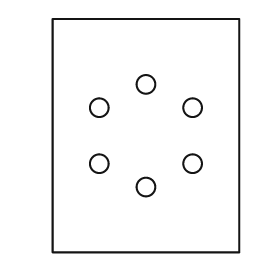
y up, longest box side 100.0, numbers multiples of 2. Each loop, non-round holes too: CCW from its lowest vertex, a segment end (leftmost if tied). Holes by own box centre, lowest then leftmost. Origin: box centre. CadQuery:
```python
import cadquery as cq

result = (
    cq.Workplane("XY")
    .moveTo(-40.0, -50.0)
    .lineTo(40.0, -50.0)
    .lineTo(40.0, 50.0)
    .lineTo(-40.0, 50.0)
    .close()
    .moveTo(0.0, -22.0)
    .circle(4.0)
    .moveTo(-20.0, -12.0)
    .circle(4.0)
    .moveTo(20.0, -12.0)
    .circle(4.0)
    .moveTo(-20.0, 12.0)
    .circle(4.0)
    .moveTo(20.0, 12.0)
    .circle(4.0)
    .moveTo(0.0, 22.0)
    .circle(4.0)
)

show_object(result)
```